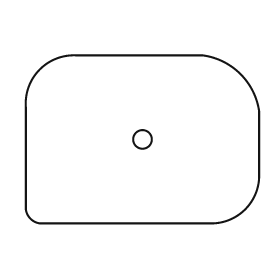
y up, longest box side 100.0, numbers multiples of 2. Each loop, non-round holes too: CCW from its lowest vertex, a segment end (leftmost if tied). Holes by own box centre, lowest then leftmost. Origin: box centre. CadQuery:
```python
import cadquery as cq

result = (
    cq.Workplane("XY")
    .moveTo(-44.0, -36.0)
    .lineTo(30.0, -36.0)
    .threePointArc((44.0, -30.0), (50.0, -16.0))
    .lineTo(50.0, 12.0)
    .threePointArc((42.0, 28.0), (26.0, 36.0))
    .lineTo(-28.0, 36.0)
    .threePointArc((-44.0, 30.0), (-50.0, 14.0))
    .lineTo(-50.0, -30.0)
    .threePointArc((-48.0, -34.0), (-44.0, -36.0))
    .close()
    .moveTo(0.0, 0.0)
    .circle(4.0)
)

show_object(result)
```